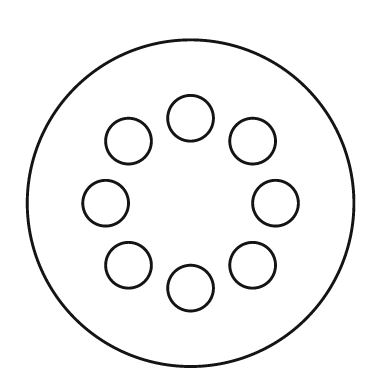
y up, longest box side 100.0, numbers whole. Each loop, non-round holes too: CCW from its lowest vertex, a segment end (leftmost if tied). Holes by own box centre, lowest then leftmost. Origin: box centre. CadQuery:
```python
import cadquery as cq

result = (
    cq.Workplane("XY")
    .moveTo(0.0, 0.0)
    .circle(50.0)
    .moveTo(0.0, -26.0)
    .circle(7.0)
    .moveTo(-19.0, -19.0)
    .circle(7.0)
    .moveTo(19.0, -19.0)
    .circle(7.0)
    .moveTo(-26.0, 0.0)
    .circle(7.0)
    .moveTo(26.0, 0.0)
    .circle(7.0)
    .moveTo(-19.0, 19.0)
    .circle(7.0)
    .moveTo(19.0, 19.0)
    .circle(7.0)
    .moveTo(0.0, 26.0)
    .circle(7.0)
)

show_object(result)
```